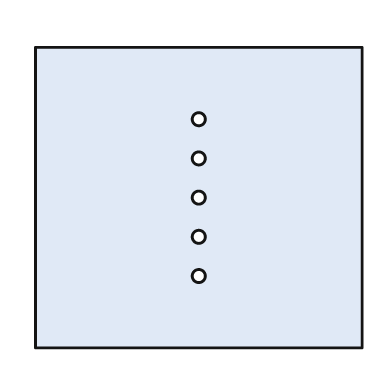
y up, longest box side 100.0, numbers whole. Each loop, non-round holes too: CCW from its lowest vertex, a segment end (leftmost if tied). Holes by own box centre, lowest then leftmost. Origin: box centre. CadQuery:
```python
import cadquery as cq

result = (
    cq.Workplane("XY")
    .moveTo(-50.0, -46.0)
    .lineTo(50.0, -46.0)
    .lineTo(50.0, 46.0)
    .lineTo(-50.0, 46.0)
    .close()
    .moveTo(0.0, -24.0)
    .circle(2.0)
    .moveTo(0.0, -12.0)
    .circle(2.0)
    .moveTo(0.0, 0.0)
    .circle(2.0)
    .moveTo(0.0, 12.0)
    .circle(2.0)
    .moveTo(0.0, 24.0)
    .circle(2.0)
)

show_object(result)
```